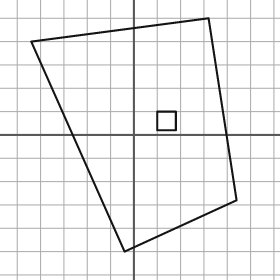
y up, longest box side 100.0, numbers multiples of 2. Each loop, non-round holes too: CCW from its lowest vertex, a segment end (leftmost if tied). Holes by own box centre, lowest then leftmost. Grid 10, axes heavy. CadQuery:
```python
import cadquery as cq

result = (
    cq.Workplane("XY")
    .moveTo(-4.0, -50.0)
    .lineTo(44.0, -28.0)
    .lineTo(32.0, 50.0)
    .lineTo(-44.0, 40.0)
    .close()
    .moveTo(10.0, 2.0)
    .lineTo(18.0, 2.0)
    .lineTo(18.0, 10.0)
    .lineTo(10.0, 10.0)
    .close()
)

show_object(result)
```